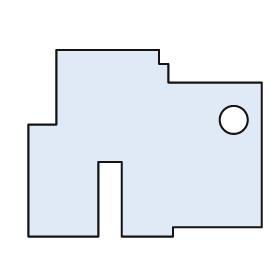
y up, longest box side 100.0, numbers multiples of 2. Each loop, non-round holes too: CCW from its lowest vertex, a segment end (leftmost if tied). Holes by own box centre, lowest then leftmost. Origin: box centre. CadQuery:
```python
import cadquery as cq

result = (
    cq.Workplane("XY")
    .moveTo(-50.0, -40.0)
    .lineTo(-20.0, -40.0)
    .lineTo(-20.0, -8.0)
    .lineTo(-10.0, -8.0)
    .lineTo(-10.0, -40.0)
    .lineTo(12.0, -40.0)
    .lineTo(12.0, -36.0)
    .lineTo(50.0, -36.0)
    .lineTo(50.0, 26.0)
    .lineTo(10.0, 26.0)
    .lineTo(10.0, 34.0)
    .lineTo(6.0, 34.0)
    .lineTo(6.0, 40.0)
    .lineTo(-38.0, 40.0)
    .lineTo(-38.0, 8.0)
    .lineTo(-50.0, 8.0)
    .close()
    .moveTo(38.0, 10.0)
    .circle(6.0)
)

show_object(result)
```